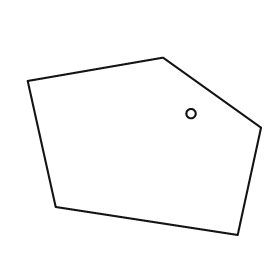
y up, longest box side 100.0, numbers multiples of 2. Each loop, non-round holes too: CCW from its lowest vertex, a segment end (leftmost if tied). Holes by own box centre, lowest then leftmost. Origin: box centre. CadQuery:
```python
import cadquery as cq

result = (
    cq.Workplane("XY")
    .moveTo(40.0, -38.0)
    .lineTo(50.0, 8.0)
    .lineTo(8.0, 38.0)
    .lineTo(-50.0, 28.0)
    .lineTo(-38.0, -26.0)
    .close()
    .moveTo(20.0, 14.0)
    .circle(2.0)
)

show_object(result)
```